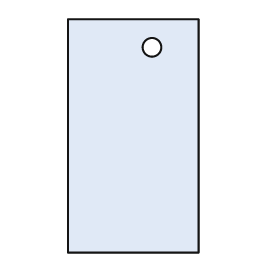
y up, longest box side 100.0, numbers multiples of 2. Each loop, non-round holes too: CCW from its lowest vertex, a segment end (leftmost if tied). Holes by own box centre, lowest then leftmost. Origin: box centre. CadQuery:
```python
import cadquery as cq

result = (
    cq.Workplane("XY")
    .moveTo(-28.0, -50.0)
    .lineTo(28.0, -50.0)
    .lineTo(28.0, 50.0)
    .lineTo(-28.0, 50.0)
    .close()
    .moveTo(8.0, 38.0)
    .circle(4.0)
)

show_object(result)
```